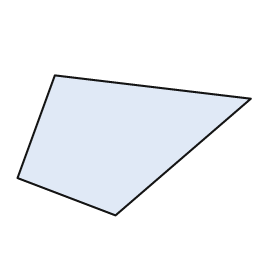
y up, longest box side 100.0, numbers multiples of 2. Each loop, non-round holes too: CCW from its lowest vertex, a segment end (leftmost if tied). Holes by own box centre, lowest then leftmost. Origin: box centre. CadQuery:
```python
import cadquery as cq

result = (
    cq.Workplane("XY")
    .moveTo(-8.0, -30.0)
    .lineTo(50.0, 20.0)
    .lineTo(-34.0, 30.0)
    .lineTo(-50.0, -14.0)
    .close()
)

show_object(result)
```